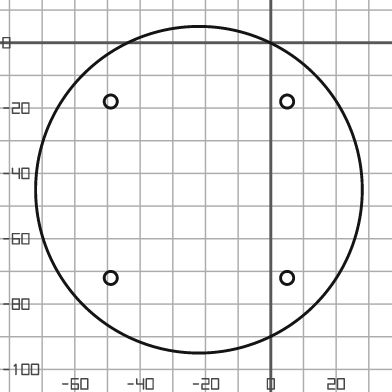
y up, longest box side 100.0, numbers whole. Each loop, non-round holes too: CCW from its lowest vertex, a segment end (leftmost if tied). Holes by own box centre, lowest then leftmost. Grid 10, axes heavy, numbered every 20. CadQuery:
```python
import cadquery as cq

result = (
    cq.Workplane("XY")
    .moveTo(-22.0, -45.0)
    .circle(50.0)
    .moveTo(-49.0, -72.0)
    .circle(2.0)
    .moveTo(5.0, -72.0)
    .circle(2.0)
    .moveTo(-49.0, -18.0)
    .circle(2.0)
    .moveTo(5.0, -18.0)
    .circle(2.0)
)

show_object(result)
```